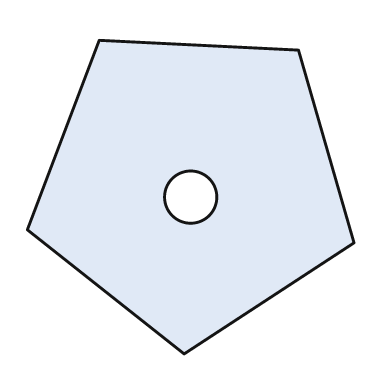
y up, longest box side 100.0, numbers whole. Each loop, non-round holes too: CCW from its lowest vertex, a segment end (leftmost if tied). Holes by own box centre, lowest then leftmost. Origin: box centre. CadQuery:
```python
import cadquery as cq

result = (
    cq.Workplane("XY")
    .moveTo(-2.0, -48.0)
    .lineTo(50.0, -14.0)
    .lineTo(33.0, 45.0)
    .lineTo(-28.0, 48.0)
    .lineTo(-50.0, -10.0)
    .close()
    .moveTo(0.0, 0.0)
    .circle(8.0)
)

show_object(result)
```